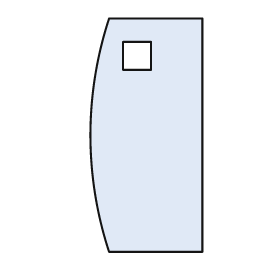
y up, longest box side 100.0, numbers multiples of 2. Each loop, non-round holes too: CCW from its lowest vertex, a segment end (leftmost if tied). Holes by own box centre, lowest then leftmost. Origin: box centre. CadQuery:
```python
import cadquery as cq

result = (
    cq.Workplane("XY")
    .moveTo(-16.0, -50.0)
    .lineTo(24.0, -50.0)
    .lineTo(24.0, 50.0)
    .lineTo(-16.0, 50.0)
    .threePointArc((-24.0, 0.0), (-16.0, -50.0))
    .close()
    .moveTo(-10.0, 28.0)
    .lineTo(2.0, 28.0)
    .lineTo(2.0, 40.0)
    .lineTo(-10.0, 40.0)
    .close()
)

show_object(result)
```